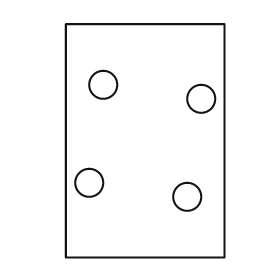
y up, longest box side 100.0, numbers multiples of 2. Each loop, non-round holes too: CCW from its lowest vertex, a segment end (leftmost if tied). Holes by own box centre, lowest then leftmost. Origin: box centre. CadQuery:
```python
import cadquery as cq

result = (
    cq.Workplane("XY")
    .moveTo(-34.0, -50.0)
    .lineTo(34.0, -50.0)
    .lineTo(34.0, 50.0)
    .lineTo(-34.0, 50.0)
    .close()
    .moveTo(18.0, -24.0)
    .circle(6.0)
    .moveTo(-24.0, -18.0)
    .circle(6.0)
    .moveTo(24.0, 18.0)
    .circle(6.0)
    .moveTo(-18.0, 24.0)
    .circle(6.0)
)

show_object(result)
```